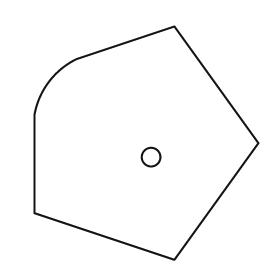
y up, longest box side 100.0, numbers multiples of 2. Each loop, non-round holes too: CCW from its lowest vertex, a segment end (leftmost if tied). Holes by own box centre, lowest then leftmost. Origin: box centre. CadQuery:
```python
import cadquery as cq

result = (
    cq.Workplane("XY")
    .moveTo(12.0, -50.0)
    .lineTo(48.0, 0.0)
    .lineTo(12.0, 50.0)
    .lineTo(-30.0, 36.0)
    .threePointArc((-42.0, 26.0), (-48.0, 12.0))
    .lineTo(-48.0, -30.0)
    .close()
    .moveTo(2.0, -6.0)
    .circle(4.0)
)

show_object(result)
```